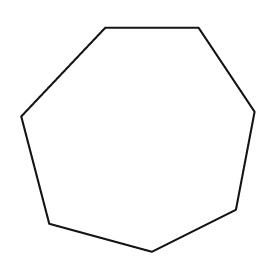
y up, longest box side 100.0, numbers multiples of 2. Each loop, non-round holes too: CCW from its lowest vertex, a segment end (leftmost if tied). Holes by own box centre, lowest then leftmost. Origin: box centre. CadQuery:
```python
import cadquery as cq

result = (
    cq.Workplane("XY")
    .moveTo(6.0, -48.0)
    .lineTo(42.0, -30.0)
    .lineTo(50.0, 12.0)
    .lineTo(26.0, 48.0)
    .lineTo(-14.0, 48.0)
    .lineTo(-50.0, 10.0)
    .lineTo(-38.0, -36.0)
    .close()
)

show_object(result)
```